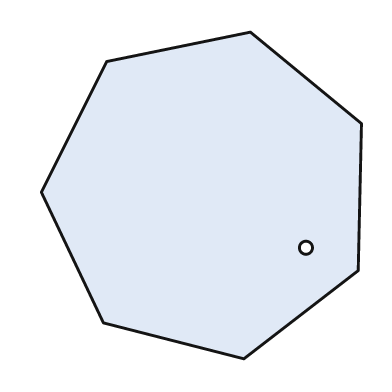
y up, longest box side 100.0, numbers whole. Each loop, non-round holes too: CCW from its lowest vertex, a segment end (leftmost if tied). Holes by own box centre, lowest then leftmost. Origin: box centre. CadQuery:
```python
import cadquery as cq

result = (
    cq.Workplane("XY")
    .moveTo(13.0, -50.0)
    .lineTo(48.0, -23.0)
    .lineTo(49.0, 22.0)
    .lineTo(15.0, 50.0)
    .lineTo(-29.0, 41.0)
    .lineTo(-49.0, 1.0)
    .lineTo(-30.0, -39.0)
    .close()
    .moveTo(32.0, -16.0)
    .circle(2.0)
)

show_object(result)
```